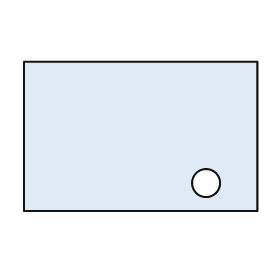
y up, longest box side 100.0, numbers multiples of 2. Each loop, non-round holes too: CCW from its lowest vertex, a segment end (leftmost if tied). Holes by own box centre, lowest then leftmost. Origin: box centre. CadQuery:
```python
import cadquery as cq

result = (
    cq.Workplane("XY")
    .moveTo(-50.0, -32.0)
    .lineTo(50.0, -32.0)
    .lineTo(50.0, 32.0)
    .lineTo(-50.0, 32.0)
    .close()
    .moveTo(28.0, -20.0)
    .circle(6.0)
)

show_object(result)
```